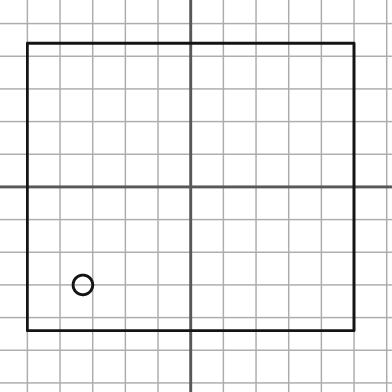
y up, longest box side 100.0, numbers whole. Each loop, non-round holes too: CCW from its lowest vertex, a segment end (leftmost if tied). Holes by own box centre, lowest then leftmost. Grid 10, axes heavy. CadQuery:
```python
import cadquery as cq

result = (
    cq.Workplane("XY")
    .moveTo(-50.0, -44.0)
    .lineTo(50.0, -44.0)
    .lineTo(50.0, 44.0)
    .lineTo(-50.0, 44.0)
    .close()
    .moveTo(-33.0, -30.0)
    .circle(3.0)
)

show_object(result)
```